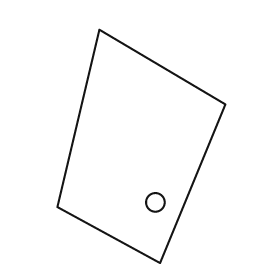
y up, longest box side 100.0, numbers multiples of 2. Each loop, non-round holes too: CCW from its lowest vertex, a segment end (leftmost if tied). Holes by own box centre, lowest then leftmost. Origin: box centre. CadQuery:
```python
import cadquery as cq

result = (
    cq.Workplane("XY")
    .moveTo(8.0, -50.0)
    .lineTo(36.0, 18.0)
    .lineTo(-18.0, 50.0)
    .lineTo(-36.0, -26.0)
    .close()
    .moveTo(6.0, -24.0)
    .circle(4.0)
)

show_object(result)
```